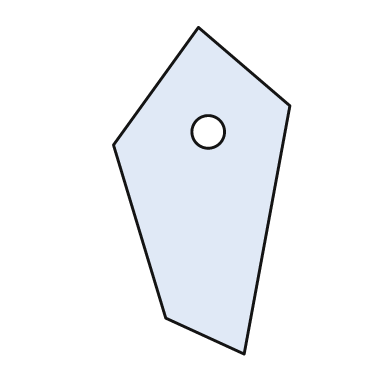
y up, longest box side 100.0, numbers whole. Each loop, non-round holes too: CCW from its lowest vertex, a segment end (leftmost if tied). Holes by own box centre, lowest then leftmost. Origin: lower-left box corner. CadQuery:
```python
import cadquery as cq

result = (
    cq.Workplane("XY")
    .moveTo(40.0, 0.0)
    .lineTo(54.0, 76.0)
    .lineTo(26.0, 100.0)
    .lineTo(0.0, 64.0)
    .lineTo(16.0, 11.0)
    .close()
    .moveTo(29.0, 68.0)
    .circle(5.0)
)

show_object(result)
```